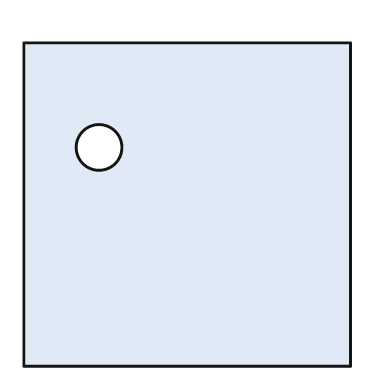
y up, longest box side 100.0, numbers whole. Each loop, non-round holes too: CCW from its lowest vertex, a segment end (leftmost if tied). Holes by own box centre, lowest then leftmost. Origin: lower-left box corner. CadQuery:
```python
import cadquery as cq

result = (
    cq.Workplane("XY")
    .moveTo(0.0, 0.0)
    .lineTo(100.0, 0.0)
    .lineTo(100.0, 99.0)
    .lineTo(0.0, 99.0)
    .close()
    .moveTo(23.0, 67.0)
    .circle(7.0)
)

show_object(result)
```